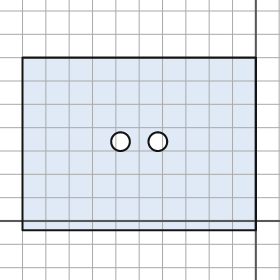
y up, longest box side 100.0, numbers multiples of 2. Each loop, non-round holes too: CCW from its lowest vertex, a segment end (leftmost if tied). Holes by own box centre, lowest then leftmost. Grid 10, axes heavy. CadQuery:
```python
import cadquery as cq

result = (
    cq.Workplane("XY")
    .moveTo(-100.0, -4.0)
    .lineTo(0.0, -4.0)
    .lineTo(0.0, 70.0)
    .lineTo(-100.0, 70.0)
    .close()
    .moveTo(-58.0, 34.0)
    .circle(4.0)
    .moveTo(-42.0, 34.0)
    .circle(4.0)
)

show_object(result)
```